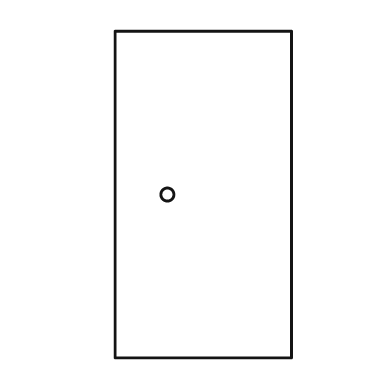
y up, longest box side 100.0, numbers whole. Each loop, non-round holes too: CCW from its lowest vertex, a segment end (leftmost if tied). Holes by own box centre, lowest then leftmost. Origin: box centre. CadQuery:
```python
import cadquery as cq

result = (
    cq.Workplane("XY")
    .moveTo(-27.0, -50.0)
    .lineTo(27.0, -50.0)
    .lineTo(27.0, 50.0)
    .lineTo(-27.0, 50.0)
    .close()
    .moveTo(-11.0, 0.0)
    .circle(2.0)
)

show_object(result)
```